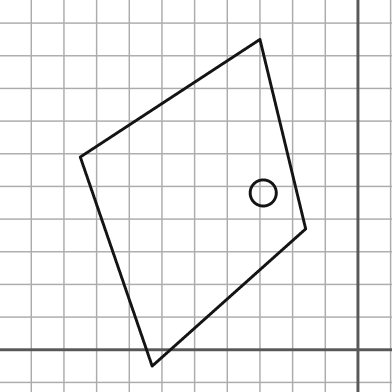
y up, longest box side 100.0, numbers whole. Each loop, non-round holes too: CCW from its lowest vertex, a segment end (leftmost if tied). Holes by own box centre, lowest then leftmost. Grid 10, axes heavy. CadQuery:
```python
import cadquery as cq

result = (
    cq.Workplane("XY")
    .moveTo(-63.0, -5.0)
    .lineTo(-16.0, 37.0)
    .lineTo(-30.0, 95.0)
    .lineTo(-85.0, 59.0)
    .close()
    .moveTo(-29.0, 48.0)
    .circle(4.0)
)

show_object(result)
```